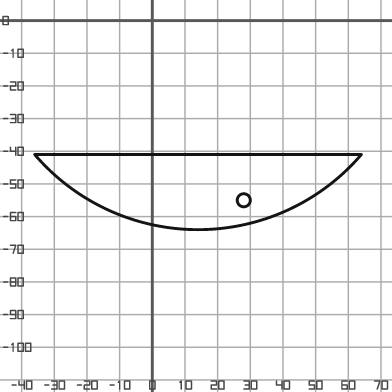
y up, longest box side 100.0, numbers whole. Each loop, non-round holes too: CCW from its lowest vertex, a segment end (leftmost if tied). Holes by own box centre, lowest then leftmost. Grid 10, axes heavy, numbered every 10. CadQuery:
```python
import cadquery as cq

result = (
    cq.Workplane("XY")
    .moveTo(-36.0, -41.0)
    .threePointArc((14.0, -64.0), (64.0, -41.0))
    .close()
    .moveTo(28.0, -55.0)
    .circle(2.0)
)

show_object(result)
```